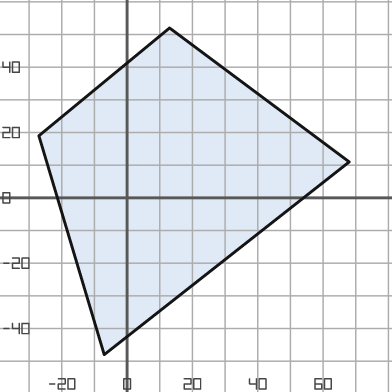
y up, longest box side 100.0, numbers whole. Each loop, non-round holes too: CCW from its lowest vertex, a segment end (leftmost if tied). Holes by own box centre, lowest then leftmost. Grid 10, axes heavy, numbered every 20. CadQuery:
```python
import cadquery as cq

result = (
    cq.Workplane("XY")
    .moveTo(-7.0, -48.0)
    .lineTo(68.0, 11.0)
    .lineTo(13.0, 52.0)
    .lineTo(-27.0, 19.0)
    .close()
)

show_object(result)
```